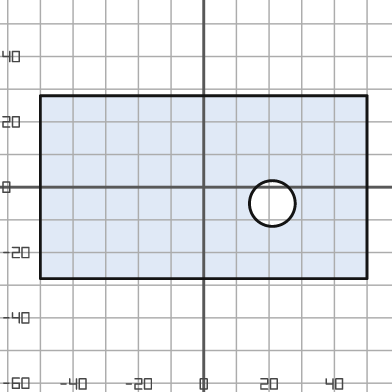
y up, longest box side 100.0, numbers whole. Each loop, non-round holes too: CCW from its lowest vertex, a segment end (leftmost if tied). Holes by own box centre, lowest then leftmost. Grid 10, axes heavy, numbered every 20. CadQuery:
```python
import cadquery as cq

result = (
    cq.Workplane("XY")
    .moveTo(-50.0, -28.0)
    .lineTo(50.0, -28.0)
    .lineTo(50.0, 28.0)
    .lineTo(-50.0, 28.0)
    .close()
    .moveTo(21.0, -5.0)
    .circle(7.0)
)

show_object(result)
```